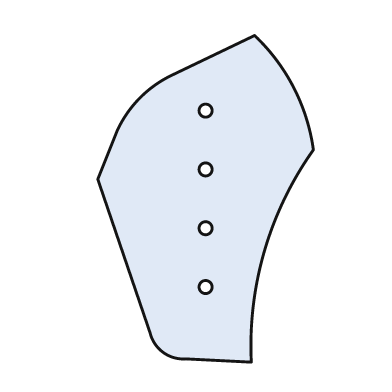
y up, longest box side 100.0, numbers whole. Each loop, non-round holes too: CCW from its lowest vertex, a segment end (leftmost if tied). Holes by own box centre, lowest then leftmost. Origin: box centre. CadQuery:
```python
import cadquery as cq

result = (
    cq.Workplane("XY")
    .moveTo(14.0, -50.0)
    .threePointArc((18.0, -16.0), (33.0, 15.0))
    .threePointArc((27.0, 34.0), (15.0, 50.0))
    .lineTo(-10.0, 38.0)
    .threePointArc((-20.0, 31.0), (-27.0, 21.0))
    .lineTo(-33.0, 6.0)
    .lineTo(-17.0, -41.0)
    .threePointArc((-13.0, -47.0), (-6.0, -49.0))
    .close()
    .moveTo(0.0, -27.0)
    .circle(2.0)
    .moveTo(0.0, -9.0)
    .circle(2.0)
    .moveTo(0.0, 9.0)
    .circle(2.0)
    .moveTo(0.0, 27.0)
    .circle(2.0)
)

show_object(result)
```